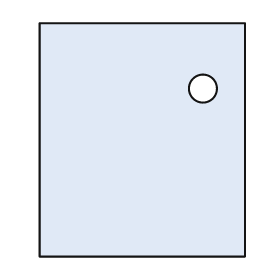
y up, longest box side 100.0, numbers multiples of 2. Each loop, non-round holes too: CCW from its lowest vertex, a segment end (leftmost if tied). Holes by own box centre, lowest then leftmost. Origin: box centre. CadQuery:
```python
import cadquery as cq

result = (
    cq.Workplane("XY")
    .moveTo(-44.0, -50.0)
    .lineTo(44.0, -50.0)
    .lineTo(44.0, 50.0)
    .lineTo(-44.0, 50.0)
    .close()
    .moveTo(26.0, 22.0)
    .circle(6.0)
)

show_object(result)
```